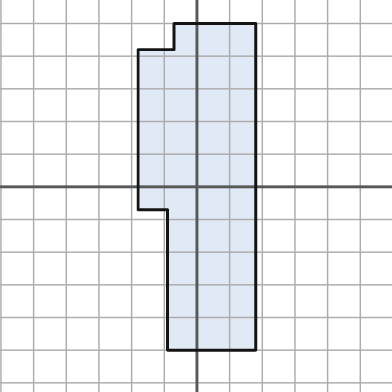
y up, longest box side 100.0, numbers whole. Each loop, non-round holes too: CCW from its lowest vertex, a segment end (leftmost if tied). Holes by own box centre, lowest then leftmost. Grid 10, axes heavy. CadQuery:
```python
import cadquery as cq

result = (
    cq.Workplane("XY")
    .moveTo(-9.0, -50.0)
    .lineTo(18.0, -50.0)
    .lineTo(18.0, 50.0)
    .lineTo(-7.0, 50.0)
    .lineTo(-7.0, 42.0)
    .lineTo(-18.0, 42.0)
    .lineTo(-18.0, -7.0)
    .lineTo(-9.0, -7.0)
    .close()
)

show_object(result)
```